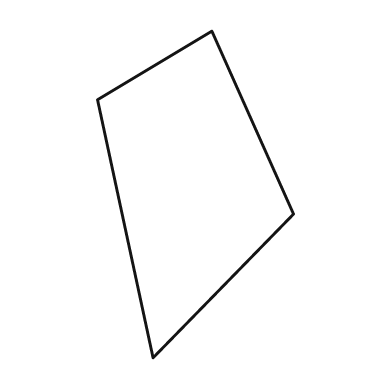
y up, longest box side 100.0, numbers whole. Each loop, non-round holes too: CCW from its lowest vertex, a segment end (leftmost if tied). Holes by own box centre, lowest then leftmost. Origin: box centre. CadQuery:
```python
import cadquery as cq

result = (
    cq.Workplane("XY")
    .moveTo(-13.0, -50.0)
    .lineTo(30.0, -6.0)
    .lineTo(5.0, 50.0)
    .lineTo(-30.0, 29.0)
    .close()
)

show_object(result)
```